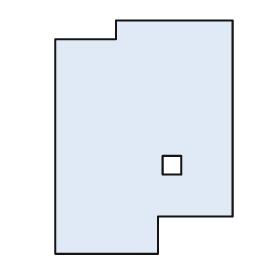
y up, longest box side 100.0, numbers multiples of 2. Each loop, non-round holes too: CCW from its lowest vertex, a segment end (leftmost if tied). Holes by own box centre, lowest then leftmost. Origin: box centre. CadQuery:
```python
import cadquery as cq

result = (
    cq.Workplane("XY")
    .moveTo(-38.0, -50.0)
    .lineTo(6.0, -50.0)
    .lineTo(6.0, -34.0)
    .lineTo(38.0, -34.0)
    .lineTo(38.0, 50.0)
    .lineTo(-12.0, 50.0)
    .lineTo(-12.0, 42.0)
    .lineTo(-38.0, 42.0)
    .close()
    .moveTo(8.0, -16.0)
    .lineTo(16.0, -16.0)
    .lineTo(16.0, -8.0)
    .lineTo(8.0, -8.0)
    .close()
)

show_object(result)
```